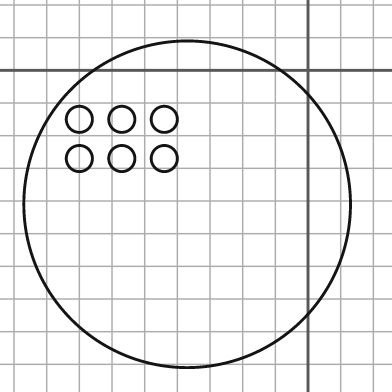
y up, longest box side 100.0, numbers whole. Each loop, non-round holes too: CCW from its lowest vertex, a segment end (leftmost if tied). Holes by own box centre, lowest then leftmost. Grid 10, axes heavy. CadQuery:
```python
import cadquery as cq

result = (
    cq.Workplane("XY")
    .moveTo(-37.0, -41.0)
    .circle(50.0)
    .moveTo(-70.0, -27.0)
    .circle(4.0)
    .moveTo(-57.0, -27.0)
    .circle(4.0)
    .moveTo(-44.0, -27.0)
    .circle(4.0)
    .moveTo(-70.0, -15.0)
    .circle(4.0)
    .moveTo(-57.0, -15.0)
    .circle(4.0)
    .moveTo(-44.0, -15.0)
    .circle(4.0)
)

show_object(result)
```